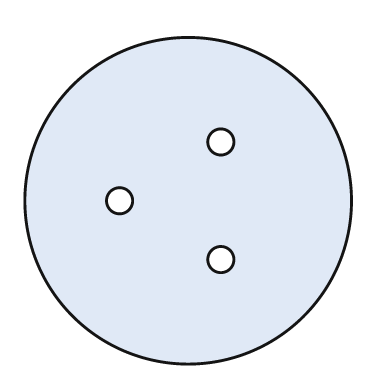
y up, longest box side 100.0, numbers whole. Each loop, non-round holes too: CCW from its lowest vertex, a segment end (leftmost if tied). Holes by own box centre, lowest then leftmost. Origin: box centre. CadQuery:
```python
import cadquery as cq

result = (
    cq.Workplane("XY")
    .moveTo(0.0, 0.0)
    .circle(50.0)
    .moveTo(10.0, -18.0)
    .circle(4.0)
    .moveTo(-21.0, 0.0)
    .circle(4.0)
    .moveTo(10.0, 18.0)
    .circle(4.0)
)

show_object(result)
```